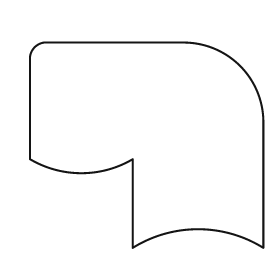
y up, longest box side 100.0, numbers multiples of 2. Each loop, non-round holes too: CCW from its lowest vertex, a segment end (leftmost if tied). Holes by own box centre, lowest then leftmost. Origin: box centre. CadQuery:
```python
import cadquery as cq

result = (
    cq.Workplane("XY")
    .moveTo(-6.0, -44.0)
    .threePointArc((22.0, -36.0), (50.0, -44.0))
    .lineTo(50.0, 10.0)
    .threePointArc((40.0, 34.0), (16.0, 44.0))
    .lineTo(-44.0, 44.0)
    .threePointArc((-48.0, 42.0), (-50.0, 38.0))
    .lineTo(-50.0, -6.0)
    .threePointArc((-28.0, -12.0), (-6.0, -6.0))
    .close()
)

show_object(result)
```